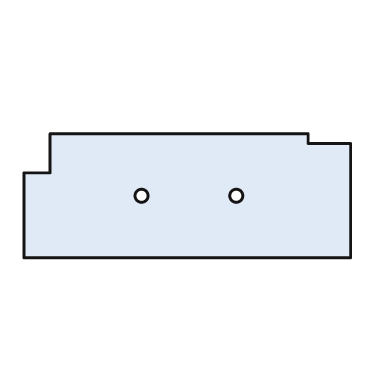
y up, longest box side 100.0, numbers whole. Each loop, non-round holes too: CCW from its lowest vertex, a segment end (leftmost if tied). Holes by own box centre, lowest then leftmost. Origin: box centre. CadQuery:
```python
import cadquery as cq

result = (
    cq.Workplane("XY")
    .moveTo(-50.0, -19.0)
    .lineTo(50.0, -19.0)
    .lineTo(50.0, 16.0)
    .lineTo(37.0, 16.0)
    .lineTo(37.0, 19.0)
    .lineTo(-42.0, 19.0)
    .lineTo(-42.0, 7.0)
    .lineTo(-50.0, 7.0)
    .close()
    .moveTo(-14.0, 0.0)
    .circle(2.0)
    .moveTo(15.0, 0.0)
    .circle(2.0)
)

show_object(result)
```